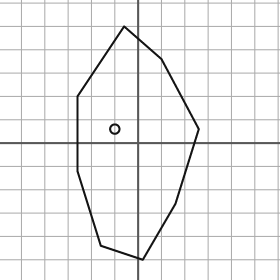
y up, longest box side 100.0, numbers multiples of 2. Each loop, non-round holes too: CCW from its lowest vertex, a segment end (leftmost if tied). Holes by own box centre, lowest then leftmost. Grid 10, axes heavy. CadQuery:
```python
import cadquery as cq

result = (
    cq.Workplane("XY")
    .moveTo(2.0, -50.0)
    .lineTo(16.0, -26.0)
    .lineTo(26.0, 6.0)
    .lineTo(10.0, 36.0)
    .lineTo(-6.0, 50.0)
    .lineTo(-26.0, 20.0)
    .lineTo(-26.0, -12.0)
    .lineTo(-16.0, -44.0)
    .close()
    .moveTo(-10.0, 6.0)
    .circle(2.0)
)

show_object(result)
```